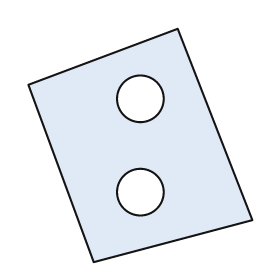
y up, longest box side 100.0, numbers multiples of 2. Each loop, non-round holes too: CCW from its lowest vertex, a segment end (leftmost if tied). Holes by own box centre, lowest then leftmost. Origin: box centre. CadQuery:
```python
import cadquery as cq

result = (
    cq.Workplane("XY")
    .moveTo(-20.0, -50.0)
    .lineTo(48.0, -32.0)
    .lineTo(16.0, 50.0)
    .lineTo(-48.0, 26.0)
    .close()
    .moveTo(0.0, -20.0)
    .circle(10.0)
    .moveTo(0.0, 20.0)
    .circle(10.0)
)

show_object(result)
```